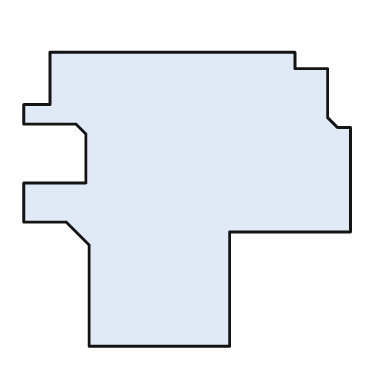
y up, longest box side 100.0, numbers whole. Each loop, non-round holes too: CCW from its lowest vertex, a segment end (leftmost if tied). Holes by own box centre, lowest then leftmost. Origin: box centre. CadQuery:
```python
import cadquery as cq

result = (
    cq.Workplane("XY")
    .moveTo(-30.0, -45.0)
    .lineTo(13.0, -45.0)
    .lineTo(13.0, -10.0)
    .lineTo(50.0, -10.0)
    .lineTo(50.0, 22.0)
    .lineTo(46.0, 22.0)
    .lineTo(43.0, 25.0)
    .lineTo(43.0, 40.0)
    .lineTo(33.0, 40.0)
    .lineTo(33.0, 45.0)
    .lineTo(-42.0, 45.0)
    .lineTo(-42.0, 29.0)
    .lineTo(-50.0, 29.0)
    .lineTo(-50.0, 23.0)
    .lineTo(-34.0, 23.0)
    .lineTo(-31.0, 20.0)
    .lineTo(-31.0, 5.0)
    .lineTo(-50.0, 5.0)
    .lineTo(-50.0, -7.0)
    .lineTo(-37.0, -7.0)
    .lineTo(-30.0, -14.0)
    .close()
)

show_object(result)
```